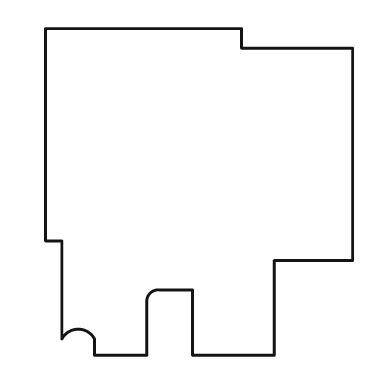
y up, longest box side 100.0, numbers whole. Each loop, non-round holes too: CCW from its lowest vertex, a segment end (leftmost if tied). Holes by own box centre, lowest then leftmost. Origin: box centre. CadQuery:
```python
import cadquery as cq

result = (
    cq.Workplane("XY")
    .moveTo(-32.0, -50.0)
    .lineTo(-16.0, -50.0)
    .lineTo(-16.0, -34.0)
    .threePointArc((-15.0, -31.0), (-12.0, -30.0))
    .lineTo(-2.0, -30.0)
    .lineTo(-2.0, -50.0)
    .lineTo(23.0, -50.0)
    .lineTo(23.0, -21.0)
    .lineTo(47.0, -21.0)
    .lineTo(47.0, 44.0)
    .lineTo(13.0, 44.0)
    .lineTo(13.0, 50.0)
    .lineTo(-47.0, 50.0)
    .lineTo(-47.0, -15.0)
    .lineTo(-42.0, -15.0)
    .lineTo(-42.0, -45.0)
    .threePointArc((-37.0, -42.0), (-32.0, -45.0))
    .close()
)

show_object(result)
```